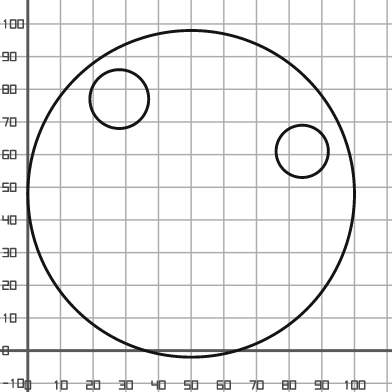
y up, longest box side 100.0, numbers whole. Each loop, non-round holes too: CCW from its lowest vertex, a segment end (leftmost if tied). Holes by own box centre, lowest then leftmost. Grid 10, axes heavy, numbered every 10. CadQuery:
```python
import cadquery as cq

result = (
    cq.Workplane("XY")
    .moveTo(50.0, 48.0)
    .circle(50.0)
    .moveTo(84.0, 61.0)
    .circle(8.0)
    .moveTo(28.0, 77.0)
    .circle(9.0)
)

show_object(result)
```